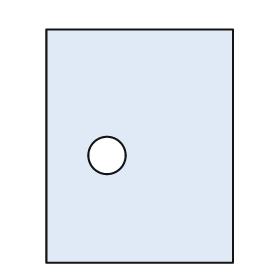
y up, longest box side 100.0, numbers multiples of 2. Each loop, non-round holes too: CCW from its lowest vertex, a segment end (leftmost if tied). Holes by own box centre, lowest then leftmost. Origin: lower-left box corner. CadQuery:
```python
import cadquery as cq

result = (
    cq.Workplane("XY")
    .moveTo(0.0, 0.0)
    .lineTo(80.0, 0.0)
    .lineTo(80.0, 100.0)
    .lineTo(0.0, 100.0)
    .close()
    .moveTo(26.0, 46.0)
    .circle(8.0)
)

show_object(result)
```